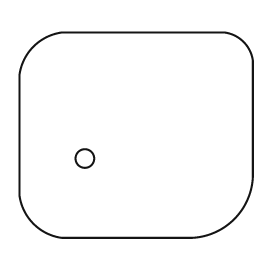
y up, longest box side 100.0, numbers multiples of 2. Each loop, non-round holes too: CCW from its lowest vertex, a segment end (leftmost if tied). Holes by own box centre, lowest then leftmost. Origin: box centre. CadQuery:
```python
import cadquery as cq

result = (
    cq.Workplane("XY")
    .moveTo(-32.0, -44.0)
    .lineTo(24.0, -44.0)
    .threePointArc((42.0, -36.0), (50.0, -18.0))
    .lineTo(50.0, 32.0)
    .threePointArc((46.0, 40.0), (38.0, 44.0))
    .lineTo(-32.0, 44.0)
    .threePointArc((-44.0, 38.0), (-50.0, 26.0))
    .lineTo(-50.0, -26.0)
    .threePointArc((-44.0, -38.0), (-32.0, -44.0))
    .close()
    .moveTo(-22.0, -10.0)
    .circle(4.0)
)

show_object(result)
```